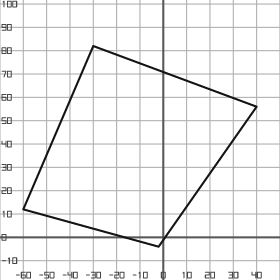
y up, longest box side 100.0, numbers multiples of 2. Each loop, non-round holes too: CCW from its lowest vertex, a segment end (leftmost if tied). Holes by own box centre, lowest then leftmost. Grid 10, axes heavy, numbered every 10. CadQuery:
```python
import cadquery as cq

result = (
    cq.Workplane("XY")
    .moveTo(-2.0, -4.0)
    .lineTo(40.0, 56.0)
    .lineTo(-30.0, 82.0)
    .lineTo(-60.0, 12.0)
    .close()
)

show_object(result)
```